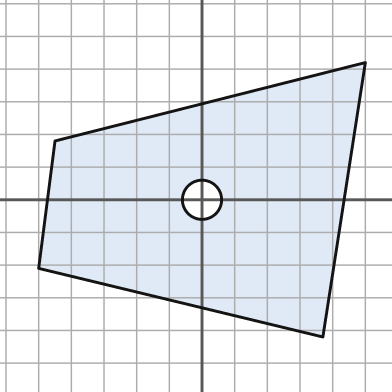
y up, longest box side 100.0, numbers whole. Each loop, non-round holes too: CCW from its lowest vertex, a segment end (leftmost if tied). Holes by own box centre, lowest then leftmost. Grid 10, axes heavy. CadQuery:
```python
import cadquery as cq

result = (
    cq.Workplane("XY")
    .moveTo(37.0, -42.0)
    .lineTo(50.0, 42.0)
    .lineTo(-45.0, 18.0)
    .lineTo(-50.0, -21.0)
    .close()
    .moveTo(0.0, 0.0)
    .circle(6.0)
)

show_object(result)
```